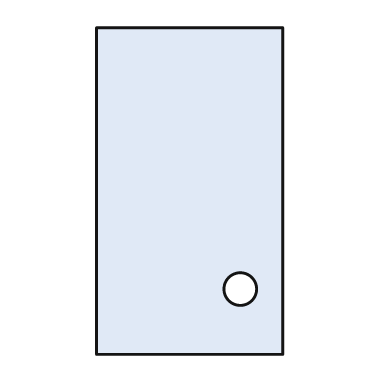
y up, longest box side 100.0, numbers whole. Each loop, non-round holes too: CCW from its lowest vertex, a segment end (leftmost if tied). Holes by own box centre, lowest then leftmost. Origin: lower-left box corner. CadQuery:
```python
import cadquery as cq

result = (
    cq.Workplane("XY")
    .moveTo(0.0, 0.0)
    .lineTo(57.0, 0.0)
    .lineTo(57.0, 100.0)
    .lineTo(0.0, 100.0)
    .close()
    .moveTo(44.0, 20.0)
    .circle(5.0)
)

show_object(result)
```